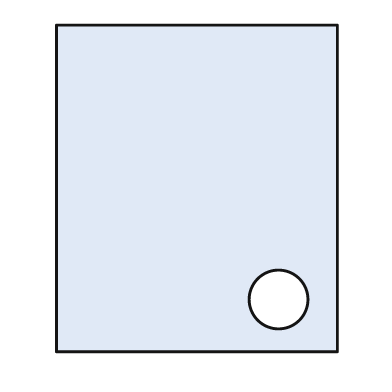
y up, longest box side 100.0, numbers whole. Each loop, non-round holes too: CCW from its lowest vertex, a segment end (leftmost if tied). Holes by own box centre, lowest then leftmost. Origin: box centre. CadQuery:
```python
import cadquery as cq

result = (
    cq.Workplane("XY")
    .moveTo(-43.0, -50.0)
    .lineTo(43.0, -50.0)
    .lineTo(43.0, 50.0)
    .lineTo(-43.0, 50.0)
    .close()
    .moveTo(25.0, -34.0)
    .circle(9.0)
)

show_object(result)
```